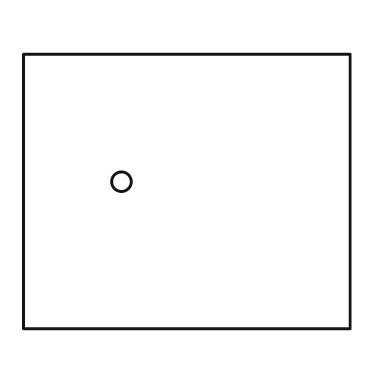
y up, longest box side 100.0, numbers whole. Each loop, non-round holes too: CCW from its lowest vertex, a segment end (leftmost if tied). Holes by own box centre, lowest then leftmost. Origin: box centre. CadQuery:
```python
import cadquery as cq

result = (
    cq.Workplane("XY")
    .moveTo(-50.0, -42.0)
    .lineTo(50.0, -42.0)
    .lineTo(50.0, 42.0)
    .lineTo(-50.0, 42.0)
    .close()
    .moveTo(-20.0, 3.0)
    .circle(3.0)
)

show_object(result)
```